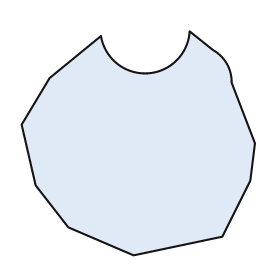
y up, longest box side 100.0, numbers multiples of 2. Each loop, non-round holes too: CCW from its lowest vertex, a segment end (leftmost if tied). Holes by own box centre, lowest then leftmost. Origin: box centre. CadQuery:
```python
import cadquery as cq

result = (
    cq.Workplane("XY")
    .moveTo(-2.0, -48.0)
    .lineTo(36.0, -40.0)
    .lineTo(48.0, -16.0)
    .lineTo(50.0, 0.0)
    .lineTo(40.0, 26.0)
    .threePointArc((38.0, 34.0), (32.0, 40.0))
    .lineTo(22.0, 48.0)
    .threePointArc((4.0, 30.0), (-16.0, 46.0))
    .lineTo(-38.0, 28.0)
    .lineTo(-50.0, 8.0)
    .lineTo(-44.0, -18.0)
    .lineTo(-30.0, -36.0)
    .close()
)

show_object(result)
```